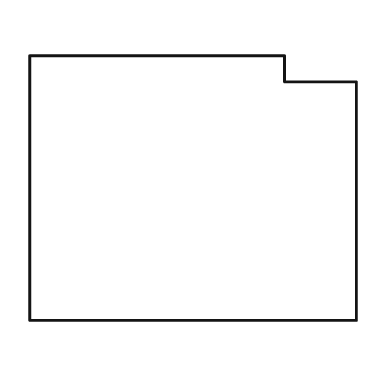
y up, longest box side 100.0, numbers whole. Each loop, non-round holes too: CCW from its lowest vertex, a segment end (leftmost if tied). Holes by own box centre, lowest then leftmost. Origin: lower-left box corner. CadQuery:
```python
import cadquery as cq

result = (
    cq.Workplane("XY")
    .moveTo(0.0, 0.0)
    .lineTo(100.0, 0.0)
    .lineTo(100.0, 73.0)
    .lineTo(78.0, 73.0)
    .lineTo(78.0, 81.0)
    .lineTo(0.0, 81.0)
    .close()
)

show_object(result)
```